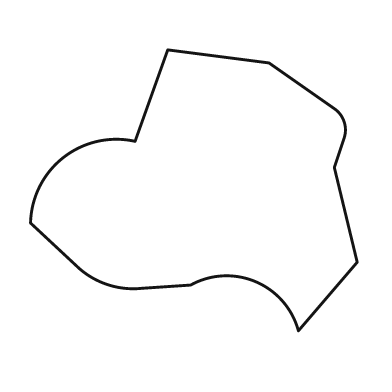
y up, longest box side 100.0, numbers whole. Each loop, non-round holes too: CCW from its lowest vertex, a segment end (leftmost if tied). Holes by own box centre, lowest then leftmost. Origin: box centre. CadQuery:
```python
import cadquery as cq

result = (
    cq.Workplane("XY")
    .moveTo(32.0, -43.0)
    .lineTo(50.0, -22.0)
    .lineTo(43.0, 7.0)
    .lineTo(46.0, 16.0)
    .threePointArc((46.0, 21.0), (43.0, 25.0))
    .lineTo(23.0, 39.0)
    .lineTo(-8.0, 43.0)
    .lineTo(-18.0, 15.0)
    .threePointArc((-40.0, 10.0), (-50.0, -10.0))
    .lineTo(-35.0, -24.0)
    .threePointArc((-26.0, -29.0), (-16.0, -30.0))
    .lineTo(-1.0, -29.0)
    .threePointArc((19.0, -28.0), (32.0, -43.0))
    .close()
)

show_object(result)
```